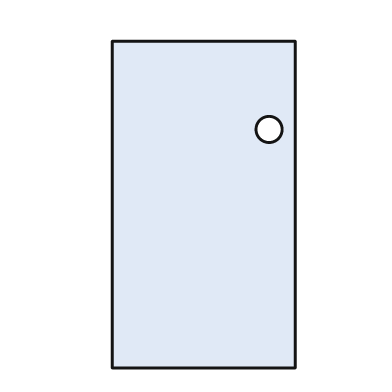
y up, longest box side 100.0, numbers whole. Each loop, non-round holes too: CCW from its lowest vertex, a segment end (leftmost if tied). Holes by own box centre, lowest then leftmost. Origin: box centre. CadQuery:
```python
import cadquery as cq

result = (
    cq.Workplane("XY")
    .moveTo(-28.0, -50.0)
    .lineTo(28.0, -50.0)
    .lineTo(28.0, 50.0)
    .lineTo(-28.0, 50.0)
    .close()
    .moveTo(20.0, 23.0)
    .circle(4.0)
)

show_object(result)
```